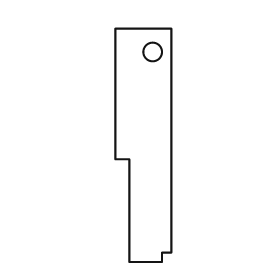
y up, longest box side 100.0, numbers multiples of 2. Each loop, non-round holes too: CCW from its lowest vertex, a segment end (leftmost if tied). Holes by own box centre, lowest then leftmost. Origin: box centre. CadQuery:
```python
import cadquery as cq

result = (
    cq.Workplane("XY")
    .moveTo(-6.0, -50.0)
    .lineTo(8.0, -50.0)
    .lineTo(8.0, -46.0)
    .lineTo(12.0, -46.0)
    .lineTo(12.0, 50.0)
    .lineTo(-12.0, 50.0)
    .lineTo(-12.0, -6.0)
    .lineTo(-6.0, -6.0)
    .close()
    .moveTo(4.0, 40.0)
    .circle(4.0)
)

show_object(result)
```